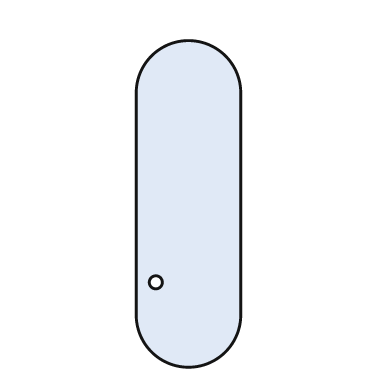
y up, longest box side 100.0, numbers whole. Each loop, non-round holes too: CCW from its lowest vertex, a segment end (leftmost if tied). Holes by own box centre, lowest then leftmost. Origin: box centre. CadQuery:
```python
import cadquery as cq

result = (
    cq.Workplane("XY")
    .moveTo(-16.0, -34.0)
    .threePointArc((0.0, -50.0), (16.0, -34.0))
    .lineTo(16.0, 34.0)
    .threePointArc((0.0, 50.0), (-16.0, 34.0))
    .close()
    .moveTo(-10.0, -24.0)
    .circle(2.0)
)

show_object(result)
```